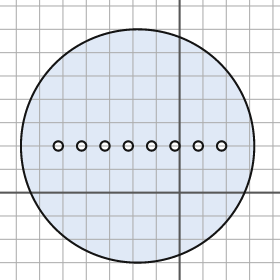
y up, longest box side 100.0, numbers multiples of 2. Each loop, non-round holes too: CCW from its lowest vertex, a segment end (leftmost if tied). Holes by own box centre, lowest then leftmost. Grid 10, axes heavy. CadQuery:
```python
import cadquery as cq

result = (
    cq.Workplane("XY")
    .moveTo(-18.0, 20.0)
    .circle(50.0)
    .moveTo(-52.0, 20.0)
    .circle(2.0)
    .moveTo(-42.0, 20.0)
    .circle(2.0)
    .moveTo(-32.0, 20.0)
    .circle(2.0)
    .moveTo(-22.0, 20.0)
    .circle(2.0)
    .moveTo(-12.0, 20.0)
    .circle(2.0)
    .moveTo(-2.0, 20.0)
    .circle(2.0)
    .moveTo(8.0, 20.0)
    .circle(2.0)
    .moveTo(18.0, 20.0)
    .circle(2.0)
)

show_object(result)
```